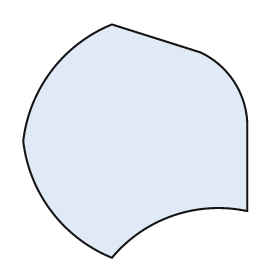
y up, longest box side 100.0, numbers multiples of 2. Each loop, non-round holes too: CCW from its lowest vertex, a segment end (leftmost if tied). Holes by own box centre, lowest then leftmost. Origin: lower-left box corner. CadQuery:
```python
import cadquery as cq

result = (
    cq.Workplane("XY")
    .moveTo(38.0, 0.0)
    .threePointArc((64.0, 18.0), (96.0, 20.0))
    .lineTo(96.0, 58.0)
    .threePointArc((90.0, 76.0), (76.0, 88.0))
    .lineTo(38.0, 100.0)
    .threePointArc((12.0, 80.0), (0.0, 50.0))
    .threePointArc((12.0, 20.0), (38.0, 0.0))
    .close()
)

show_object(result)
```